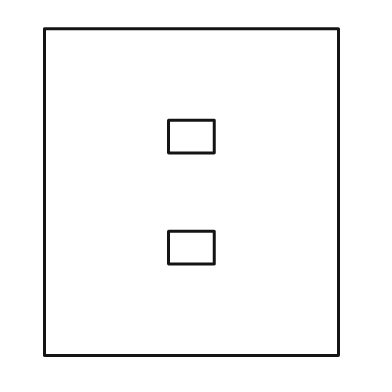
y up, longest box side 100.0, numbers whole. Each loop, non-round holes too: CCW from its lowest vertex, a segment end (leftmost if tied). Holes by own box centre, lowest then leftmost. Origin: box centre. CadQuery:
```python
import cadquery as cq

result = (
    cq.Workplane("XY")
    .moveTo(-45.0, -50.0)
    .lineTo(45.0, -50.0)
    .lineTo(45.0, 50.0)
    .lineTo(-45.0, 50.0)
    .close()
    .moveTo(-7.0, -22.0)
    .lineTo(7.0, -22.0)
    .lineTo(7.0, -12.0)
    .lineTo(-7.0, -12.0)
    .close()
    .moveTo(-7.0, 12.0)
    .lineTo(7.0, 12.0)
    .lineTo(7.0, 22.0)
    .lineTo(-7.0, 22.0)
    .close()
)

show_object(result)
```